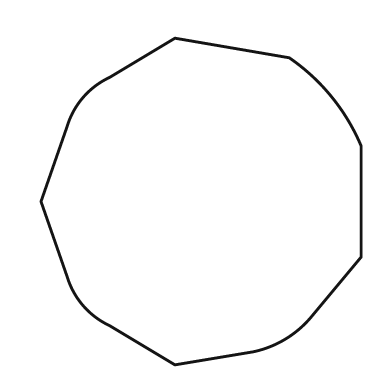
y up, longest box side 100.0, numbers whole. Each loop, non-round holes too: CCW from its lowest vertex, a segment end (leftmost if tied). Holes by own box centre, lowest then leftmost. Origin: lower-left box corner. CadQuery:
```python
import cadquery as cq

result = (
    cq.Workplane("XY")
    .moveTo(41.0, 0.0)
    .lineTo(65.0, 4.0)
    .threePointArc((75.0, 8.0), (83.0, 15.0))
    .lineTo(98.0, 33.0)
    .lineTo(98.0, 67.0)
    .threePointArc((89.0, 82.0), (76.0, 94.0))
    .lineTo(41.0, 100.0)
    .lineTo(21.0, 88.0)
    .threePointArc((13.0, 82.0), (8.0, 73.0))
    .lineTo(0.0, 50.0)
    .lineTo(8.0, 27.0)
    .threePointArc((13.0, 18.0), (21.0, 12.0))
    .close()
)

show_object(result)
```